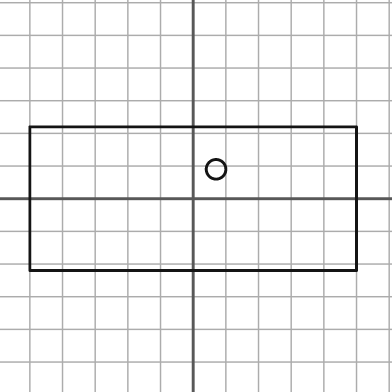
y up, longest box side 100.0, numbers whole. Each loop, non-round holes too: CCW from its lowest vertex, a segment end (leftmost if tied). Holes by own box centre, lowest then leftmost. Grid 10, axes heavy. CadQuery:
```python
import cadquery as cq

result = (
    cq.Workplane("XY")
    .moveTo(-50.0, -22.0)
    .lineTo(50.0, -22.0)
    .lineTo(50.0, 22.0)
    .lineTo(-50.0, 22.0)
    .close()
    .moveTo(7.0, 9.0)
    .circle(3.0)
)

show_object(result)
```